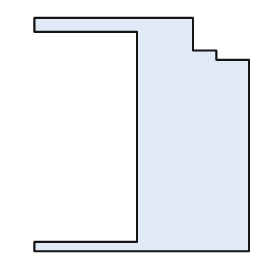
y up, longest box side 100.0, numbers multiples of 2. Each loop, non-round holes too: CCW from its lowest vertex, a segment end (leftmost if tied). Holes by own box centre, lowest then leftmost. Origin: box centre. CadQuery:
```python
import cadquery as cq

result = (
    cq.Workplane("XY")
    .moveTo(-46.0, -50.0)
    .lineTo(46.0, -50.0)
    .lineTo(46.0, 32.0)
    .lineTo(32.0, 32.0)
    .lineTo(32.0, 36.0)
    .lineTo(22.0, 36.0)
    .lineTo(22.0, 50.0)
    .lineTo(-46.0, 50.0)
    .lineTo(-46.0, 44.0)
    .lineTo(-2.0, 44.0)
    .lineTo(-2.0, -46.0)
    .lineTo(-46.0, -46.0)
    .close()
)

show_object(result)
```